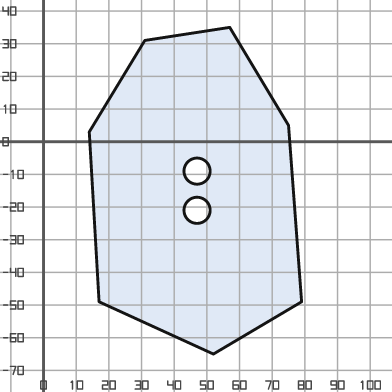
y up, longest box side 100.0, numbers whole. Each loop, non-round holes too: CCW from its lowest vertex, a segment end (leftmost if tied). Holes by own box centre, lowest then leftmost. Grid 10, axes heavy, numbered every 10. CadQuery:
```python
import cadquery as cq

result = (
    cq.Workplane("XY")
    .moveTo(52.0, -65.0)
    .lineTo(79.0, -49.0)
    .lineTo(75.0, 5.0)
    .lineTo(57.0, 35.0)
    .lineTo(31.0, 31.0)
    .lineTo(14.0, 3.0)
    .lineTo(17.0, -49.0)
    .close()
    .moveTo(47.0, -21.0)
    .circle(4.0)
    .moveTo(47.0, -9.0)
    .circle(4.0)
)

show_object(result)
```